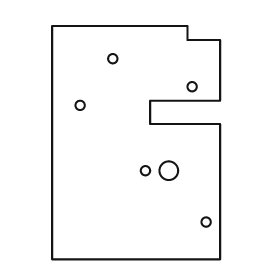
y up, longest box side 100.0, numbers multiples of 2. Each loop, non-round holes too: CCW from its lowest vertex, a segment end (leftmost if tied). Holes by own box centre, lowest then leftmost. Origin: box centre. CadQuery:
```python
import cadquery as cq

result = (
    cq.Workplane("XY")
    .moveTo(-36.0, -50.0)
    .lineTo(36.0, -50.0)
    .lineTo(36.0, 8.0)
    .lineTo(6.0, 8.0)
    .lineTo(6.0, 18.0)
    .lineTo(36.0, 18.0)
    .lineTo(36.0, 44.0)
    .lineTo(22.0, 44.0)
    .lineTo(22.0, 50.0)
    .lineTo(-36.0, 50.0)
    .close()
    .moveTo(30.0, -34.0)
    .circle(2.0)
    .moveTo(4.0, -12.0)
    .circle(2.0)
    .moveTo(14.0, -12.0)
    .circle(4.0)
    .moveTo(-24.0, 16.0)
    .circle(2.0)
    .moveTo(24.0, 24.0)
    .circle(2.0)
    .moveTo(-10.0, 36.0)
    .circle(2.0)
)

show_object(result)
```